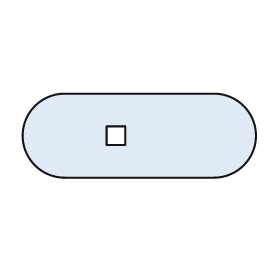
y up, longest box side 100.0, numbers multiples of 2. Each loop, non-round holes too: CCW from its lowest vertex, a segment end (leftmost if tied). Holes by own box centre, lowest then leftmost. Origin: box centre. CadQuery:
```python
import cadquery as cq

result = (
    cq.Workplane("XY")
    .moveTo(-32.0, -18.0)
    .lineTo(32.0, -18.0)
    .threePointArc((50.0, 0.0), (32.0, 18.0))
    .lineTo(-32.0, 18.0)
    .threePointArc((-50.0, 0.0), (-32.0, -18.0))
    .close()
    .moveTo(-14.0, -4.0)
    .lineTo(-6.0, -4.0)
    .lineTo(-6.0, 4.0)
    .lineTo(-14.0, 4.0)
    .close()
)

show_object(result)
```